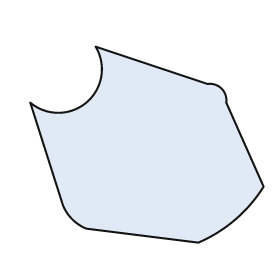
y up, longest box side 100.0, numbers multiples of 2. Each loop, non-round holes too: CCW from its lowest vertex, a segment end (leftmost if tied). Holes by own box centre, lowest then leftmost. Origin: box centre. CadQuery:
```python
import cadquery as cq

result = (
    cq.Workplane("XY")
    .moveTo(22.0, -42.0)
    .threePointArc((38.0, -32.0), (50.0, -18.0))
    .lineTo(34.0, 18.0)
    .threePointArc((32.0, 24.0), (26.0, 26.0))
    .lineTo(-22.0, 42.0)
    .threePointArc((-26.0, 18.0), (-50.0, 18.0))
    .lineTo(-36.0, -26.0)
    .threePointArc((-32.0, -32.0), (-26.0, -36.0))
    .close()
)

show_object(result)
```